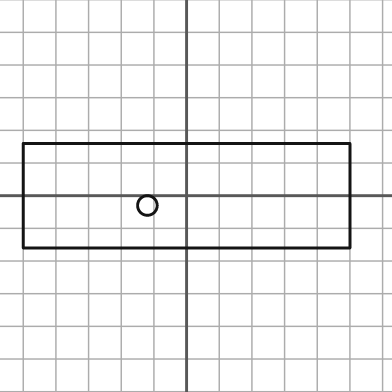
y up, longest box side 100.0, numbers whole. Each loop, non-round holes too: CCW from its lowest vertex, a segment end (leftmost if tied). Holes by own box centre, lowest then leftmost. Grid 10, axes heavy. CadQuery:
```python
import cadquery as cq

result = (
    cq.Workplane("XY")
    .moveTo(-50.0, -16.0)
    .lineTo(50.0, -16.0)
    .lineTo(50.0, 16.0)
    .lineTo(-50.0, 16.0)
    .close()
    .moveTo(-12.0, -3.0)
    .circle(3.0)
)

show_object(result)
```